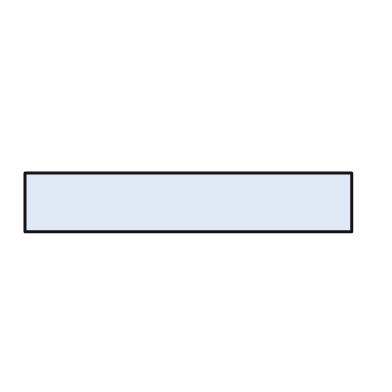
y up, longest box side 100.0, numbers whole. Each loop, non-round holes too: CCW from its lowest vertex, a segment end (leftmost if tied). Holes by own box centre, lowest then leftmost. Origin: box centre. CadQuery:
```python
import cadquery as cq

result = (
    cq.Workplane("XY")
    .moveTo(-50.0, -9.0)
    .lineTo(50.0, -9.0)
    .lineTo(50.0, 9.0)
    .lineTo(-50.0, 9.0)
    .close()
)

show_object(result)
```